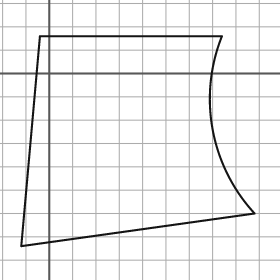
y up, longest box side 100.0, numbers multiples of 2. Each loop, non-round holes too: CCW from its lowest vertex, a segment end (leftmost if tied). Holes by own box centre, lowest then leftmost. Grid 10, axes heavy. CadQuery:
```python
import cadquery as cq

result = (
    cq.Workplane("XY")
    .moveTo(-12.0, -74.0)
    .lineTo(88.0, -60.0)
    .threePointArc((70.0, -24.0), (74.0, 16.0))
    .lineTo(-4.0, 16.0)
    .close()
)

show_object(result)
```